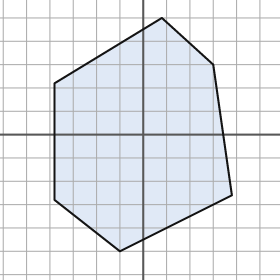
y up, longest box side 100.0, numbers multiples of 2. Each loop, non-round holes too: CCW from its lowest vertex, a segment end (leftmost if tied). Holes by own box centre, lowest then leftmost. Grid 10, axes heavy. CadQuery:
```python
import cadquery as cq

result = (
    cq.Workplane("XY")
    .moveTo(-10.0, -50.0)
    .lineTo(38.0, -26.0)
    .lineTo(30.0, 30.0)
    .lineTo(8.0, 50.0)
    .lineTo(-38.0, 22.0)
    .lineTo(-38.0, -28.0)
    .close()
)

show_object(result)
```